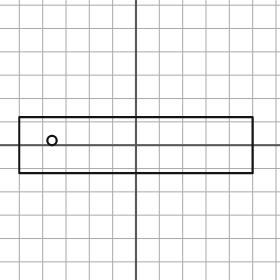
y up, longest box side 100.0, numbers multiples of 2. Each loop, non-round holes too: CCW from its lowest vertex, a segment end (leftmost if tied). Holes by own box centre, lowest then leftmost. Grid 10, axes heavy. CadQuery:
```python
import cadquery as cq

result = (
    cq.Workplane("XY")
    .moveTo(-50.0, -12.0)
    .lineTo(50.0, -12.0)
    .lineTo(50.0, 12.0)
    .lineTo(-50.0, 12.0)
    .close()
    .moveTo(-36.0, 2.0)
    .circle(2.0)
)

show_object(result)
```